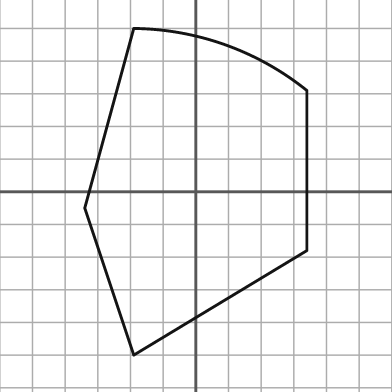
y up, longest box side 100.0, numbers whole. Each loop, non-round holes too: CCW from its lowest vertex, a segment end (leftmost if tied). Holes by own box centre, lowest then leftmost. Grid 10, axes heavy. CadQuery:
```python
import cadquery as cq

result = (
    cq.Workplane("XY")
    .moveTo(-19.0, -50.0)
    .lineTo(34.0, -18.0)
    .lineTo(34.0, 31.0)
    .threePointArc((9.0, 45.0), (-19.0, 50.0))
    .lineTo(-34.0, -5.0)
    .close()
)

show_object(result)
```